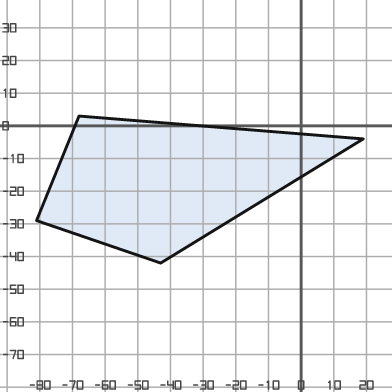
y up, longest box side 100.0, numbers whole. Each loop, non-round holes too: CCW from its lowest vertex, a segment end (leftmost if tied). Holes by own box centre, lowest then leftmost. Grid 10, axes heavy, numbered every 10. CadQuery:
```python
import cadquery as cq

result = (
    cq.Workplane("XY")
    .moveTo(-43.0, -42.0)
    .lineTo(19.0, -4.0)
    .lineTo(-68.0, 3.0)
    .lineTo(-81.0, -29.0)
    .close()
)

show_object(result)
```